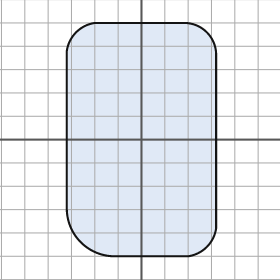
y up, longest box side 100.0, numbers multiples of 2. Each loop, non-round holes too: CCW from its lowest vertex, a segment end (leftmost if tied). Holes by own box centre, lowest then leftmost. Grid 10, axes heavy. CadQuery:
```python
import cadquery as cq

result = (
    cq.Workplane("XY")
    .moveTo(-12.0, -50.0)
    .lineTo(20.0, -50.0)
    .threePointArc((28.0, -46.0), (32.0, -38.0))
    .lineTo(32.0, 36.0)
    .threePointArc((28.0, 46.0), (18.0, 50.0))
    .lineTo(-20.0, 50.0)
    .threePointArc((-28.0, 46.0), (-32.0, 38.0))
    .lineTo(-32.0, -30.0)
    .threePointArc((-26.0, -44.0), (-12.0, -50.0))
    .close()
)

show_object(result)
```